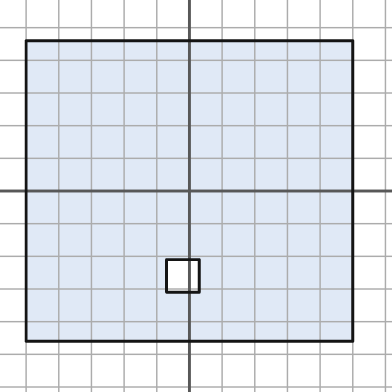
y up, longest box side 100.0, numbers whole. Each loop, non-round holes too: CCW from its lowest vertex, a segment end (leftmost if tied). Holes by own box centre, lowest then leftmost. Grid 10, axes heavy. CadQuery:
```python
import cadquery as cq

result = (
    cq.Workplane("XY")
    .moveTo(-50.0, -46.0)
    .lineTo(50.0, -46.0)
    .lineTo(50.0, 46.0)
    .lineTo(-50.0, 46.0)
    .close()
    .moveTo(-7.0, -31.0)
    .lineTo(3.0, -31.0)
    .lineTo(3.0, -21.0)
    .lineTo(-7.0, -21.0)
    .close()
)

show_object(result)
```